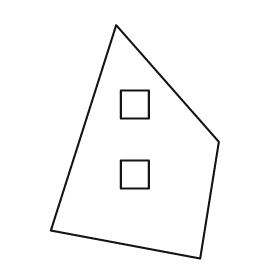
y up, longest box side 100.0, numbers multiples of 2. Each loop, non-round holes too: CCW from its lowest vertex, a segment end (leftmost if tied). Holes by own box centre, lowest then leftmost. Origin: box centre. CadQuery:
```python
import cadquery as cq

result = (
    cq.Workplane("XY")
    .moveTo(28.0, -50.0)
    .lineTo(36.0, 0.0)
    .lineTo(-8.0, 50.0)
    .lineTo(-36.0, -38.0)
    .close()
    .moveTo(-6.0, -20.0)
    .lineTo(6.0, -20.0)
    .lineTo(6.0, -8.0)
    .lineTo(-6.0, -8.0)
    .close()
    .moveTo(-6.0, 10.0)
    .lineTo(6.0, 10.0)
    .lineTo(6.0, 22.0)
    .lineTo(-6.0, 22.0)
    .close()
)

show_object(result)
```